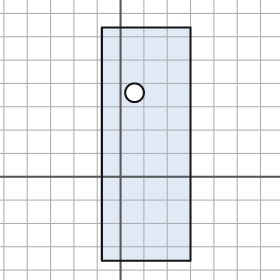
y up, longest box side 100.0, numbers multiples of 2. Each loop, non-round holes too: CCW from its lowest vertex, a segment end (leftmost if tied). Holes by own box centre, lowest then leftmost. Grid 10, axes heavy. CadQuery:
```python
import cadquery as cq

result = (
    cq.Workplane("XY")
    .moveTo(-8.0, -36.0)
    .lineTo(30.0, -36.0)
    .lineTo(30.0, 64.0)
    .lineTo(-8.0, 64.0)
    .close()
    .moveTo(6.0, 36.0)
    .circle(4.0)
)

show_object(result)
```